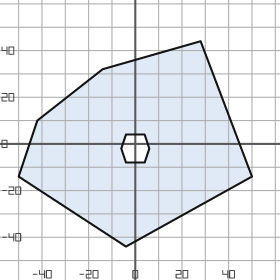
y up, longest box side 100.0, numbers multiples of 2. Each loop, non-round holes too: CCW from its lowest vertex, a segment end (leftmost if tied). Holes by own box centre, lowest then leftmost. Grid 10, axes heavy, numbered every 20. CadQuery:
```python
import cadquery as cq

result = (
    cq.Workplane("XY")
    .moveTo(-4.0, -44.0)
    .lineTo(50.0, -14.0)
    .lineTo(28.0, 44.0)
    .lineTo(-14.0, 32.0)
    .lineTo(-42.0, 10.0)
    .lineTo(-50.0, -14.0)
    .close()
    .moveTo(-4.0, -8.0)
    .lineTo(4.0, -8.0)
    .lineTo(6.0, -2.0)
    .lineTo(4.0, 4.0)
    .lineTo(-4.0, 4.0)
    .lineTo(-6.0, -2.0)
    .close()
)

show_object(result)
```